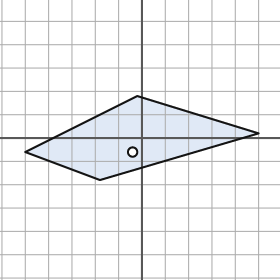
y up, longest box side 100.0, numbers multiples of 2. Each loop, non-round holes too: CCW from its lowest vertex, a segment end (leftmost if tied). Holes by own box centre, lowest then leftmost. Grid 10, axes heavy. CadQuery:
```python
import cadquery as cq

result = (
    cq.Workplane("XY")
    .moveTo(-18.0, -18.0)
    .lineTo(50.0, 2.0)
    .lineTo(-2.0, 18.0)
    .lineTo(-50.0, -6.0)
    .close()
    .moveTo(-4.0, -6.0)
    .circle(2.0)
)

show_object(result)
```